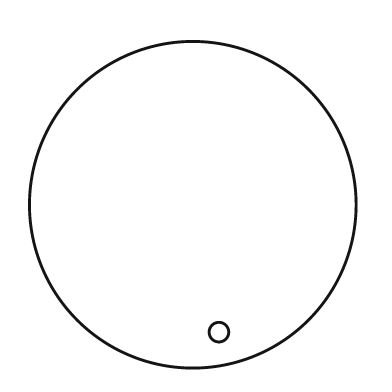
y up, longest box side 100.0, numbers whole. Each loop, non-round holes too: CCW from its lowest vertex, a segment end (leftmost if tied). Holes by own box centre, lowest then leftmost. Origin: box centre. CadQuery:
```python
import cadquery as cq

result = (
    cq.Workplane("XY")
    .moveTo(0.0, 0.0)
    .circle(50.0)
    .moveTo(8.0, -39.0)
    .circle(3.0)
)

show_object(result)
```